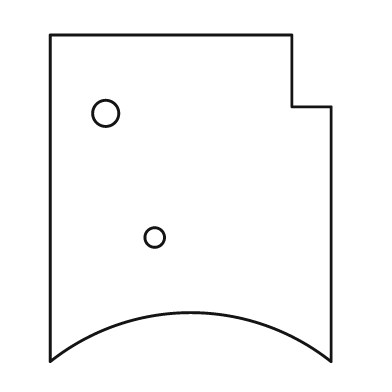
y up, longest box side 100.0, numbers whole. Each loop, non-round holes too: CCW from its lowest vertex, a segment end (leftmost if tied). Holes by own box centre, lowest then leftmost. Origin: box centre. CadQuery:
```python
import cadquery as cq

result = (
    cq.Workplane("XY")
    .moveTo(-43.0, -50.0)
    .threePointArc((0.0, -35.0), (43.0, -50.0))
    .lineTo(43.0, 28.0)
    .lineTo(31.0, 28.0)
    .lineTo(31.0, 50.0)
    .lineTo(-43.0, 50.0)
    .close()
    .moveTo(-11.0, -12.0)
    .circle(3.0)
    .moveTo(-26.0, 26.0)
    .circle(4.0)
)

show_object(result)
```